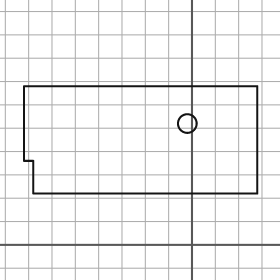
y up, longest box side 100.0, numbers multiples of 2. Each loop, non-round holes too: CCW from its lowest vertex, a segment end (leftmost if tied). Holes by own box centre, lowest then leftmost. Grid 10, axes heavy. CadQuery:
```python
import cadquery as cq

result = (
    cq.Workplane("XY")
    .moveTo(-68.0, 22.0)
    .lineTo(28.0, 22.0)
    .lineTo(28.0, 68.0)
    .lineTo(-72.0, 68.0)
    .lineTo(-72.0, 36.0)
    .lineTo(-68.0, 36.0)
    .close()
    .moveTo(-2.0, 52.0)
    .circle(4.0)
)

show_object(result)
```